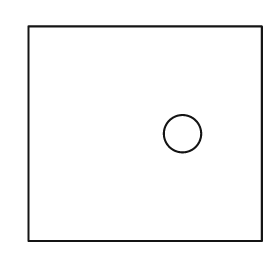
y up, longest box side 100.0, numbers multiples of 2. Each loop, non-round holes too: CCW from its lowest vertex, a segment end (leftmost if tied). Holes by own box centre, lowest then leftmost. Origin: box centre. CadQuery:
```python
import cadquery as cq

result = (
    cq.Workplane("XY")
    .moveTo(-50.0, -46.0)
    .lineTo(50.0, -46.0)
    .lineTo(50.0, 46.0)
    .lineTo(-50.0, 46.0)
    .close()
    .moveTo(16.0, 0.0)
    .circle(8.0)
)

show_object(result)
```